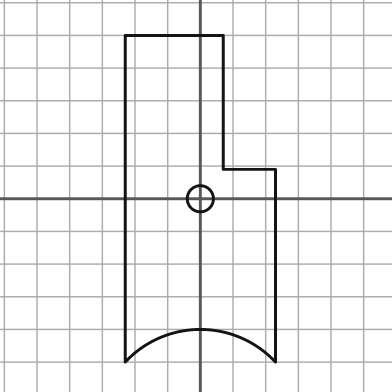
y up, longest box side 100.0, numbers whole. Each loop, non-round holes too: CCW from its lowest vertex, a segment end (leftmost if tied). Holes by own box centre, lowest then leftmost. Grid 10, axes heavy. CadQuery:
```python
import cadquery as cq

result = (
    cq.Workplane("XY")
    .moveTo(-23.0, -50.0)
    .threePointArc((0.0, -40.0), (23.0, -50.0))
    .lineTo(23.0, 9.0)
    .lineTo(7.0, 9.0)
    .lineTo(7.0, 50.0)
    .lineTo(-23.0, 50.0)
    .close()
    .moveTo(0.0, 0.0)
    .circle(4.0)
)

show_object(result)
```